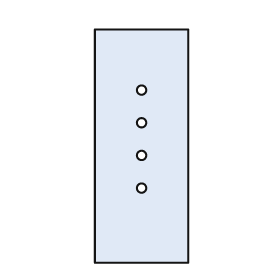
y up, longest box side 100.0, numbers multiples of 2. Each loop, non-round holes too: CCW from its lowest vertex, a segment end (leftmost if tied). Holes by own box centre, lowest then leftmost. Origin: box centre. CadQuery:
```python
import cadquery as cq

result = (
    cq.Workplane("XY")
    .moveTo(-20.0, -50.0)
    .lineTo(20.0, -50.0)
    .lineTo(20.0, 50.0)
    .lineTo(-20.0, 50.0)
    .close()
    .moveTo(0.0, -18.0)
    .circle(2.0)
    .moveTo(0.0, -4.0)
    .circle(2.0)
    .moveTo(0.0, 10.0)
    .circle(2.0)
    .moveTo(0.0, 24.0)
    .circle(2.0)
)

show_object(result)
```